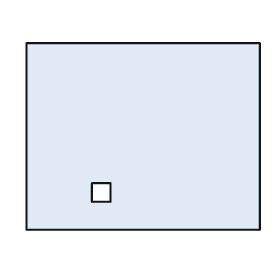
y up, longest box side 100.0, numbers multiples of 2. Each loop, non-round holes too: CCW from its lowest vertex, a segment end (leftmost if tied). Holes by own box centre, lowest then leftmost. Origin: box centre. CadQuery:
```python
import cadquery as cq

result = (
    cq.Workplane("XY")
    .moveTo(-50.0, -40.0)
    .lineTo(50.0, -40.0)
    .lineTo(50.0, 40.0)
    .lineTo(-50.0, 40.0)
    .close()
    .moveTo(-22.0, -28.0)
    .lineTo(-14.0, -28.0)
    .lineTo(-14.0, -20.0)
    .lineTo(-22.0, -20.0)
    .close()
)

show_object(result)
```